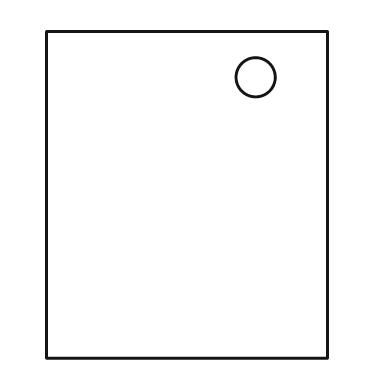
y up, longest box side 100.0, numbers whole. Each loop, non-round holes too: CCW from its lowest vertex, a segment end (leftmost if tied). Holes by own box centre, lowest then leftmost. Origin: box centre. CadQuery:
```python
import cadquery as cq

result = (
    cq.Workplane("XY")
    .moveTo(-43.0, -50.0)
    .lineTo(43.0, -50.0)
    .lineTo(43.0, 50.0)
    .lineTo(-43.0, 50.0)
    .close()
    .moveTo(21.0, 36.0)
    .circle(6.0)
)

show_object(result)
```